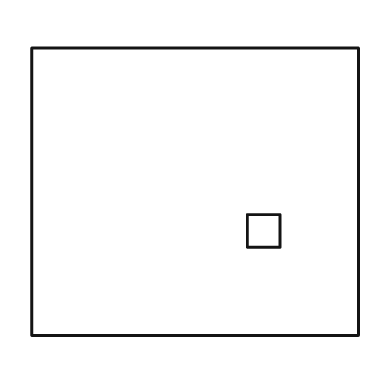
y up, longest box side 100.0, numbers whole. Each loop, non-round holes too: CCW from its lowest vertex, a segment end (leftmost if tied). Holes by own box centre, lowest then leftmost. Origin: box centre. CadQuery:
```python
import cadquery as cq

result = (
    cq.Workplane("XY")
    .moveTo(-50.0, -44.0)
    .lineTo(50.0, -44.0)
    .lineTo(50.0, 44.0)
    .lineTo(-50.0, 44.0)
    .close()
    .moveTo(16.0, -17.0)
    .lineTo(26.0, -17.0)
    .lineTo(26.0, -7.0)
    .lineTo(16.0, -7.0)
    .close()
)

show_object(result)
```